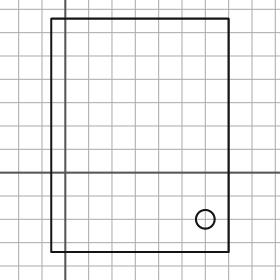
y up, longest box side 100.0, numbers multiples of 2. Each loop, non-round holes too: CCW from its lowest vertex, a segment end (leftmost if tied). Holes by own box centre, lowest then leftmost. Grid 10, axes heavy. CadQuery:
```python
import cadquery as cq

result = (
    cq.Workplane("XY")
    .moveTo(-6.0, -34.0)
    .lineTo(70.0, -34.0)
    .lineTo(70.0, 66.0)
    .lineTo(-6.0, 66.0)
    .close()
    .moveTo(60.0, -20.0)
    .circle(4.0)
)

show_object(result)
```